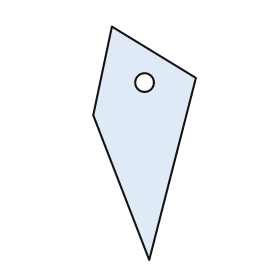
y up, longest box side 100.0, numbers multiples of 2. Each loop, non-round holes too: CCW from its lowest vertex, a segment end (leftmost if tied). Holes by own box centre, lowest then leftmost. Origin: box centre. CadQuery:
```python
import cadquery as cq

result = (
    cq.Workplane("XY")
    .moveTo(2.0, -50.0)
    .lineTo(22.0, 28.0)
    .lineTo(-14.0, 50.0)
    .lineTo(-22.0, 12.0)
    .close()
    .moveTo(0.0, 26.0)
    .circle(4.0)
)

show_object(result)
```